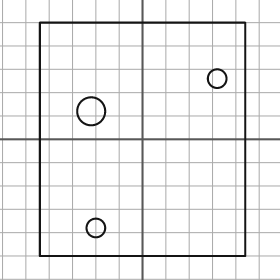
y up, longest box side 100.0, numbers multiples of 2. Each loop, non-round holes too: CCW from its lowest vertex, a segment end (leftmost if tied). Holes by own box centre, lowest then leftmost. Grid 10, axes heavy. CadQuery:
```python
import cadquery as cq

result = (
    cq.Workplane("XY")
    .moveTo(-44.0, -50.0)
    .lineTo(44.0, -50.0)
    .lineTo(44.0, 50.0)
    .lineTo(-44.0, 50.0)
    .close()
    .moveTo(-20.0, -38.0)
    .circle(4.0)
    .moveTo(-22.0, 12.0)
    .circle(6.0)
    .moveTo(32.0, 26.0)
    .circle(4.0)
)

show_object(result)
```